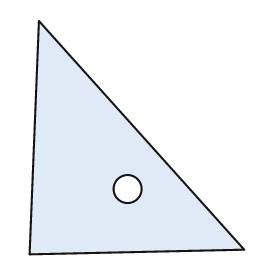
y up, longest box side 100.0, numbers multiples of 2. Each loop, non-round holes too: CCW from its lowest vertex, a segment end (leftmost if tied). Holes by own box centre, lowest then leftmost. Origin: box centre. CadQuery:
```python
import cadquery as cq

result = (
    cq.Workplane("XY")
    .moveTo(-46.0, -50.0)
    .lineTo(46.0, -48.0)
    .lineTo(-42.0, 50.0)
    .close()
    .moveTo(-4.0, -22.0)
    .circle(6.0)
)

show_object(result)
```